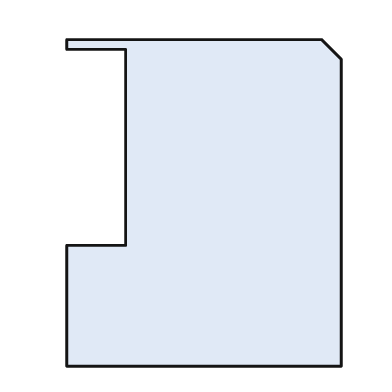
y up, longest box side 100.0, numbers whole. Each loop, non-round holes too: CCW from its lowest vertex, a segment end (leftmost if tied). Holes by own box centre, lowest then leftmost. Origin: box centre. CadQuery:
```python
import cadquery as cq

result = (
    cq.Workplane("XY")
    .moveTo(-42.0, -50.0)
    .lineTo(42.0, -50.0)
    .lineTo(42.0, 44.0)
    .lineTo(36.0, 50.0)
    .lineTo(-42.0, 50.0)
    .lineTo(-42.0, 47.0)
    .lineTo(-24.0, 47.0)
    .lineTo(-24.0, -13.0)
    .lineTo(-42.0, -13.0)
    .close()
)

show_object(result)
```